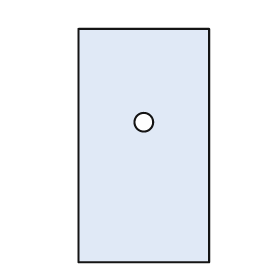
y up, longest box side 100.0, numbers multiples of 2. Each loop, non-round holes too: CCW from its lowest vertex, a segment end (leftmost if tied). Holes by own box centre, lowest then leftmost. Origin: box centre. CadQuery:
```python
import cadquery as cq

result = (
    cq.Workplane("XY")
    .moveTo(-28.0, -50.0)
    .lineTo(28.0, -50.0)
    .lineTo(28.0, 50.0)
    .lineTo(-28.0, 50.0)
    .close()
    .moveTo(0.0, 10.0)
    .circle(4.0)
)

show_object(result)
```